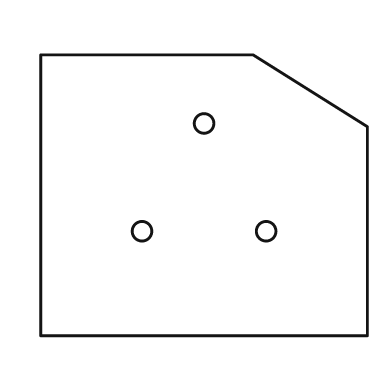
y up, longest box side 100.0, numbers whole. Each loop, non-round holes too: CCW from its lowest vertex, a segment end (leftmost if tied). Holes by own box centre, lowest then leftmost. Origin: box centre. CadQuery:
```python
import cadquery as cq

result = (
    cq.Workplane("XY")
    .moveTo(-50.0, -43.0)
    .lineTo(50.0, -43.0)
    .lineTo(50.0, 21.0)
    .lineTo(15.0, 43.0)
    .lineTo(-50.0, 43.0)
    .close()
    .moveTo(-19.0, -11.0)
    .circle(3.0)
    .moveTo(19.0, -11.0)
    .circle(3.0)
    .moveTo(0.0, 22.0)
    .circle(3.0)
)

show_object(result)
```